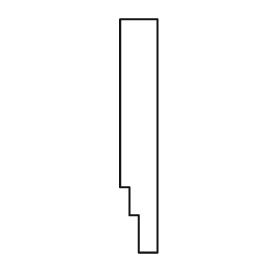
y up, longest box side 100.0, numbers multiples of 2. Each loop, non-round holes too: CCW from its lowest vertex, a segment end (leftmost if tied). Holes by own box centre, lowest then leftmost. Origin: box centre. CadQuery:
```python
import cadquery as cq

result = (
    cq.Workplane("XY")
    .moveTo(0.0, -50.0)
    .lineTo(8.0, -50.0)
    .lineTo(8.0, 50.0)
    .lineTo(-8.0, 50.0)
    .lineTo(-8.0, -22.0)
    .lineTo(-4.0, -22.0)
    .lineTo(-4.0, -34.0)
    .lineTo(0.0, -34.0)
    .close()
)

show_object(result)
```